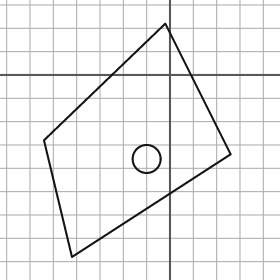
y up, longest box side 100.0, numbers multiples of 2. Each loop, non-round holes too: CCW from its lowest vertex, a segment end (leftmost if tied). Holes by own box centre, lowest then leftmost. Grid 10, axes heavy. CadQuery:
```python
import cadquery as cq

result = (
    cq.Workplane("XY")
    .moveTo(-42.0, -78.0)
    .lineTo(26.0, -34.0)
    .lineTo(-2.0, 22.0)
    .lineTo(-54.0, -28.0)
    .close()
    .moveTo(-10.0, -36.0)
    .circle(6.0)
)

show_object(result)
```